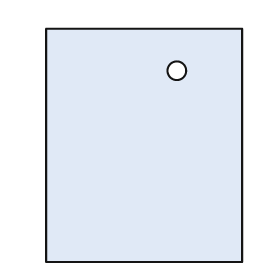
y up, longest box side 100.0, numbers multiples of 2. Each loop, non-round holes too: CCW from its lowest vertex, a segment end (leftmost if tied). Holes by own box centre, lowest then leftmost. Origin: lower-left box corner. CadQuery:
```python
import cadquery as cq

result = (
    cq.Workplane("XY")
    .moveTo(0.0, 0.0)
    .lineTo(84.0, 0.0)
    .lineTo(84.0, 100.0)
    .lineTo(0.0, 100.0)
    .close()
    .moveTo(56.0, 82.0)
    .circle(4.0)
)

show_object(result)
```